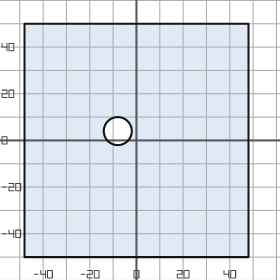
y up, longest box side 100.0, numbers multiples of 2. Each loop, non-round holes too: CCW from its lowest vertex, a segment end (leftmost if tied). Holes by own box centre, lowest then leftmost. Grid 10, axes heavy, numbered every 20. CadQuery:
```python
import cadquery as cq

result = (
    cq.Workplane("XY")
    .moveTo(-48.0, -50.0)
    .lineTo(48.0, -50.0)
    .lineTo(48.0, 50.0)
    .lineTo(-48.0, 50.0)
    .close()
    .moveTo(-8.0, 4.0)
    .circle(6.0)
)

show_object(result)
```